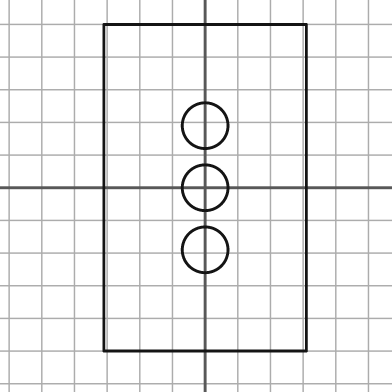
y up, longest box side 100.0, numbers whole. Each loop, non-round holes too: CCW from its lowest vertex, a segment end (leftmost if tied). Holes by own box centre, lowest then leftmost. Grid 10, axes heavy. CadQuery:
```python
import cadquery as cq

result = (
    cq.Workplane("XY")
    .moveTo(-31.0, -50.0)
    .lineTo(31.0, -50.0)
    .lineTo(31.0, 50.0)
    .lineTo(-31.0, 50.0)
    .close()
    .moveTo(0.0, -19.0)
    .circle(7.0)
    .moveTo(0.0, 0.0)
    .circle(7.0)
    .moveTo(0.0, 19.0)
    .circle(7.0)
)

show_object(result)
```